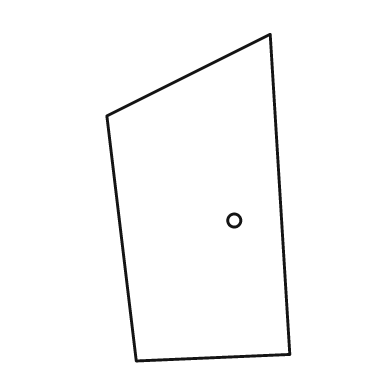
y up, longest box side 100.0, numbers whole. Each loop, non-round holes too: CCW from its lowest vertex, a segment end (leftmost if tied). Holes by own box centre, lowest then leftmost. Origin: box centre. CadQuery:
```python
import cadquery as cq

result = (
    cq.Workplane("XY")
    .moveTo(-19.0, -50.0)
    .lineTo(28.0, -48.0)
    .lineTo(22.0, 50.0)
    .lineTo(-28.0, 25.0)
    .close()
    .moveTo(11.0, -7.0)
    .circle(2.0)
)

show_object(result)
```